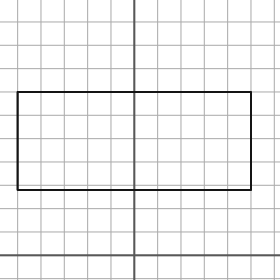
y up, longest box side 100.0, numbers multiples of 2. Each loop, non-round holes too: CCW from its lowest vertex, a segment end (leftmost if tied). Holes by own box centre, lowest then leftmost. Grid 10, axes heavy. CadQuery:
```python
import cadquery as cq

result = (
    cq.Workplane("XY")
    .moveTo(-50.0, 28.0)
    .lineTo(50.0, 28.0)
    .lineTo(50.0, 70.0)
    .lineTo(-50.0, 70.0)
    .close()
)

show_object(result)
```